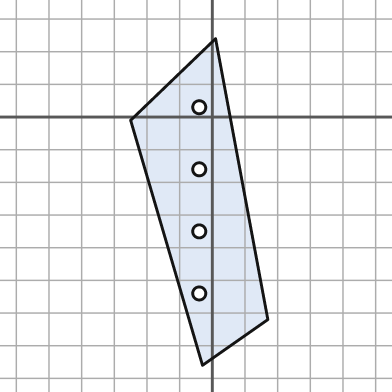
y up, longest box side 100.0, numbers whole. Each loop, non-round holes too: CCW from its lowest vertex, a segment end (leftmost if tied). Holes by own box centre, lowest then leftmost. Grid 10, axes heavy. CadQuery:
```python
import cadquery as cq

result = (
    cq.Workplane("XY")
    .moveTo(-3.0, -76.0)
    .lineTo(17.0, -62.0)
    .lineTo(1.0, 24.0)
    .lineTo(-25.0, -1.0)
    .close()
    .moveTo(-4.0, -54.0)
    .circle(2.0)
    .moveTo(-4.0, -35.0)
    .circle(2.0)
    .moveTo(-4.0, -16.0)
    .circle(2.0)
    .moveTo(-4.0, 3.0)
    .circle(2.0)
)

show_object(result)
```